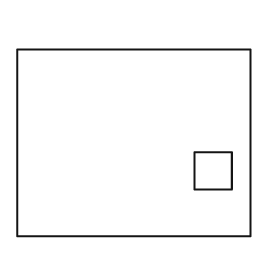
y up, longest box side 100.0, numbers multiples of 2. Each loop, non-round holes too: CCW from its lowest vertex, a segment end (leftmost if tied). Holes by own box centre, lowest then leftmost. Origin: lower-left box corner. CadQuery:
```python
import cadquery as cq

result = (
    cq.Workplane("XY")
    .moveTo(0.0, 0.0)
    .lineTo(100.0, 0.0)
    .lineTo(100.0, 80.0)
    .lineTo(0.0, 80.0)
    .close()
    .moveTo(76.0, 20.0)
    .lineTo(92.0, 20.0)
    .lineTo(92.0, 36.0)
    .lineTo(76.0, 36.0)
    .close()
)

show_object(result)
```